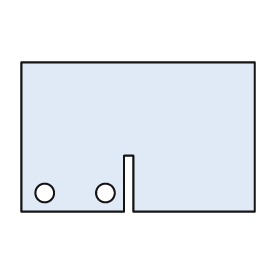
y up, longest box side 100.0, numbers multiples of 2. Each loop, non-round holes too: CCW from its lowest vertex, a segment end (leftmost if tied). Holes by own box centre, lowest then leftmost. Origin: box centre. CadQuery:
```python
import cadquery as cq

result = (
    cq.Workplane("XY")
    .moveTo(-50.0, -32.0)
    .lineTo(-6.0, -32.0)
    .lineTo(-6.0, -8.0)
    .lineTo(-2.0, -8.0)
    .lineTo(-2.0, -32.0)
    .lineTo(50.0, -32.0)
    .lineTo(50.0, 32.0)
    .lineTo(-50.0, 32.0)
    .close()
    .moveTo(-40.0, -24.0)
    .circle(4.0)
    .moveTo(-14.0, -24.0)
    .circle(4.0)
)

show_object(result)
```